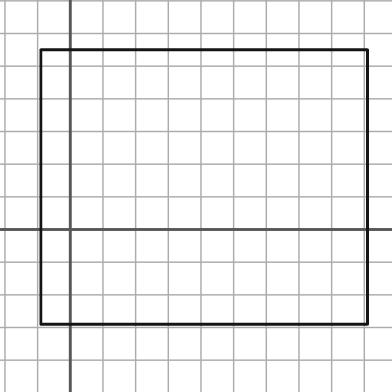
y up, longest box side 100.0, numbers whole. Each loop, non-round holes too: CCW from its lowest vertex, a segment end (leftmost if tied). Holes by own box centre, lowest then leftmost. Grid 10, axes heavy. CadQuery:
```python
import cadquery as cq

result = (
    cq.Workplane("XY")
    .moveTo(-9.0, -29.0)
    .lineTo(91.0, -29.0)
    .lineTo(91.0, 55.0)
    .lineTo(-9.0, 55.0)
    .close()
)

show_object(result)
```